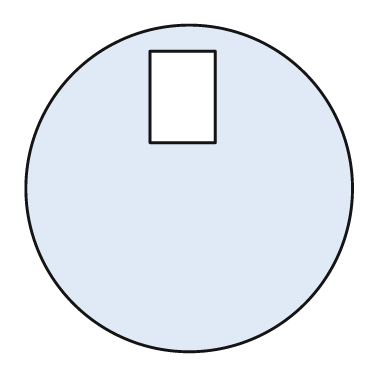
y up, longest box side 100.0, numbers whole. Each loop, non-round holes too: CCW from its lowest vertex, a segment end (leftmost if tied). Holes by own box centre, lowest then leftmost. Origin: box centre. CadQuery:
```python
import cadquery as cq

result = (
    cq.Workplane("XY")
    .moveTo(0.0, 0.0)
    .circle(50.0)
    .moveTo(-12.0, 14.0)
    .lineTo(8.0, 14.0)
    .lineTo(8.0, 42.0)
    .lineTo(-12.0, 42.0)
    .close()
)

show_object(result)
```